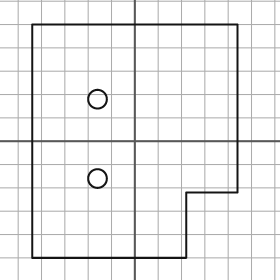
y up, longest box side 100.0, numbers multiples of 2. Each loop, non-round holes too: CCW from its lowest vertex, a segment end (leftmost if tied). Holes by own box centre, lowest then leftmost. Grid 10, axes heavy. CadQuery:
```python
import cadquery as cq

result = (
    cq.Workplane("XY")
    .moveTo(-44.0, -50.0)
    .lineTo(22.0, -50.0)
    .lineTo(22.0, -22.0)
    .lineTo(44.0, -22.0)
    .lineTo(44.0, 50.0)
    .lineTo(-44.0, 50.0)
    .close()
    .moveTo(-16.0, -16.0)
    .circle(4.0)
    .moveTo(-16.0, 18.0)
    .circle(4.0)
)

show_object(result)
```